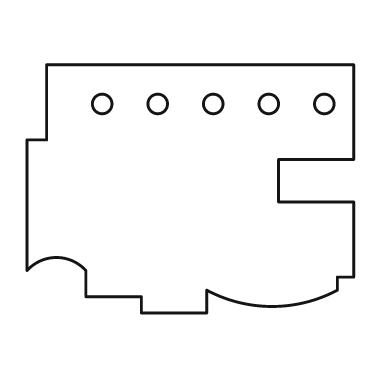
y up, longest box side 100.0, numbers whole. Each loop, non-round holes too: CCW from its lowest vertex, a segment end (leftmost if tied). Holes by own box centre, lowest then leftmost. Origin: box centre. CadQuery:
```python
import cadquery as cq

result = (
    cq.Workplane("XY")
    .moveTo(-15.0, -38.0)
    .lineTo(5.0, -38.0)
    .lineTo(5.0, -31.0)
    .threePointArc((25.0, -36.0), (45.0, -31.0))
    .lineTo(45.0, -27.0)
    .lineTo(50.0, -27.0)
    .lineTo(50.0, -4.0)
    .lineTo(27.0, -4.0)
    .lineTo(27.0, 9.0)
    .lineTo(50.0, 9.0)
    .lineTo(50.0, 38.0)
    .lineTo(-44.0, 38.0)
    .lineTo(-44.0, 15.0)
    .lineTo(-50.0, 15.0)
    .lineTo(-50.0, -25.0)
    .threePointArc((-41.0, -21.0), (-32.0, -25.0))
    .lineTo(-32.0, -33.0)
    .lineTo(-15.0, -33.0)
    .close()
    .moveTo(-27.0, 26.0)
    .circle(3.0)
    .moveTo(-10.0, 26.0)
    .circle(3.0)
    .moveTo(7.0, 26.0)
    .circle(3.0)
    .moveTo(24.0, 26.0)
    .circle(3.0)
    .moveTo(41.0, 26.0)
    .circle(3.0)
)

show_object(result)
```